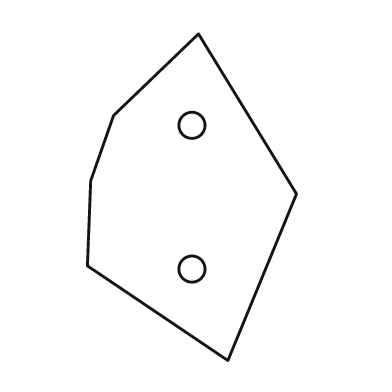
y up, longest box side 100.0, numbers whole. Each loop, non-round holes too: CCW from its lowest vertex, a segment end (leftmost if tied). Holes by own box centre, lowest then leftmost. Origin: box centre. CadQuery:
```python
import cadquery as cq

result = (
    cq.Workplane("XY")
    .moveTo(11.0, -50.0)
    .lineTo(32.0, 1.0)
    .lineTo(2.0, 50.0)
    .lineTo(-24.0, 25.0)
    .lineTo(-31.0, 5.0)
    .lineTo(-32.0, -21.0)
    .close()
    .moveTo(0.0, -22.0)
    .circle(4.0)
    .moveTo(0.0, 22.0)
    .circle(4.0)
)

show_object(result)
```